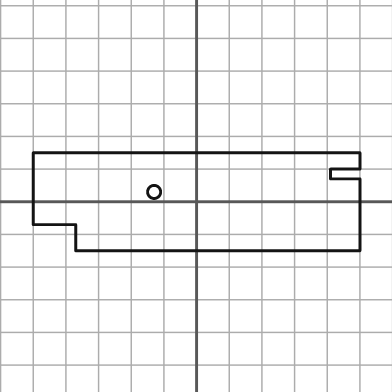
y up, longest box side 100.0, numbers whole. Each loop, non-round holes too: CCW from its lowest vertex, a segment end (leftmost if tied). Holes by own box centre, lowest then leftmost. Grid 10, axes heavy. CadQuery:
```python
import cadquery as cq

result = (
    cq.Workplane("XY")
    .moveTo(-37.0, -15.0)
    .lineTo(50.0, -15.0)
    .lineTo(50.0, 7.0)
    .lineTo(41.0, 7.0)
    .lineTo(41.0, 10.0)
    .lineTo(50.0, 10.0)
    .lineTo(50.0, 15.0)
    .lineTo(-50.0, 15.0)
    .lineTo(-50.0, -7.0)
    .lineTo(-37.0, -7.0)
    .close()
    .moveTo(-13.0, 3.0)
    .circle(2.0)
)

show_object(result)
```